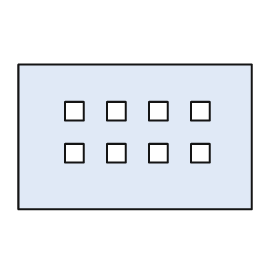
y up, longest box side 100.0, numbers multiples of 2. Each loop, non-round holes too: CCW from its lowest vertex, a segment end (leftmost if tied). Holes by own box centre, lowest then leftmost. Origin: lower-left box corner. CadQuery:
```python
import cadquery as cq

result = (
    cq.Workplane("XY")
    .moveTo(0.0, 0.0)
    .lineTo(100.0, 0.0)
    .lineTo(100.0, 62.0)
    .lineTo(0.0, 62.0)
    .close()
    .moveTo(20.0, 20.0)
    .lineTo(28.0, 20.0)
    .lineTo(28.0, 28.0)
    .lineTo(20.0, 28.0)
    .close()
    .moveTo(38.0, 20.0)
    .lineTo(46.0, 20.0)
    .lineTo(46.0, 28.0)
    .lineTo(38.0, 28.0)
    .close()
    .moveTo(56.0, 20.0)
    .lineTo(64.0, 20.0)
    .lineTo(64.0, 28.0)
    .lineTo(56.0, 28.0)
    .close()
    .moveTo(74.0, 20.0)
    .lineTo(82.0, 20.0)
    .lineTo(82.0, 28.0)
    .lineTo(74.0, 28.0)
    .close()
    .moveTo(20.0, 38.0)
    .lineTo(28.0, 38.0)
    .lineTo(28.0, 46.0)
    .lineTo(20.0, 46.0)
    .close()
    .moveTo(38.0, 38.0)
    .lineTo(46.0, 38.0)
    .lineTo(46.0, 46.0)
    .lineTo(38.0, 46.0)
    .close()
    .moveTo(56.0, 38.0)
    .lineTo(64.0, 38.0)
    .lineTo(64.0, 46.0)
    .lineTo(56.0, 46.0)
    .close()
    .moveTo(74.0, 38.0)
    .lineTo(82.0, 38.0)
    .lineTo(82.0, 46.0)
    .lineTo(74.0, 46.0)
    .close()
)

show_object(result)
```